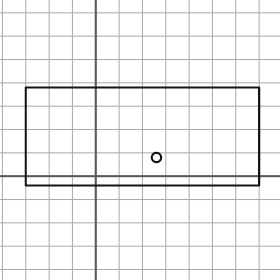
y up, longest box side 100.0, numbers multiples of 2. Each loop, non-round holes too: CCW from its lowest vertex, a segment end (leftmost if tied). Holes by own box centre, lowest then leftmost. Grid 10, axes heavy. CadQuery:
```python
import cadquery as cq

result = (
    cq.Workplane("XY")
    .moveTo(-30.0, -4.0)
    .lineTo(70.0, -4.0)
    .lineTo(70.0, 38.0)
    .lineTo(-30.0, 38.0)
    .close()
    .moveTo(26.0, 8.0)
    .circle(2.0)
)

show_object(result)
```